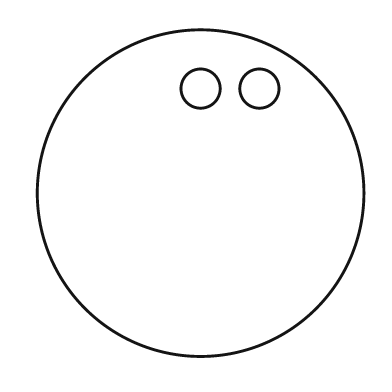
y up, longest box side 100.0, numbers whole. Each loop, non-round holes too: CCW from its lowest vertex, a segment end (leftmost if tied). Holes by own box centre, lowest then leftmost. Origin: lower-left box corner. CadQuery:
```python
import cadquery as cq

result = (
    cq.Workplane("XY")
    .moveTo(50.0, 50.0)
    .circle(50.0)
    .moveTo(50.0, 82.0)
    .circle(6.0)
    .moveTo(68.0, 82.0)
    .circle(6.0)
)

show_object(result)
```